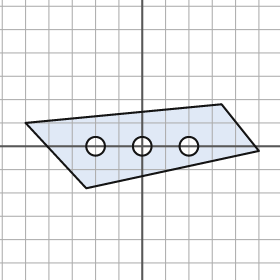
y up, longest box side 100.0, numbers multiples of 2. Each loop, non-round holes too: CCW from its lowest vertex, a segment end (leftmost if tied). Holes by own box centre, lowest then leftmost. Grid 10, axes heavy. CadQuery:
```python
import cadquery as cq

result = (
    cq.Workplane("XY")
    .moveTo(-24.0, -18.0)
    .lineTo(50.0, -2.0)
    .lineTo(34.0, 18.0)
    .lineTo(-50.0, 10.0)
    .close()
    .moveTo(-20.0, 0.0)
    .circle(4.0)
    .moveTo(0.0, 0.0)
    .circle(4.0)
    .moveTo(20.0, 0.0)
    .circle(4.0)
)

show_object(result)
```